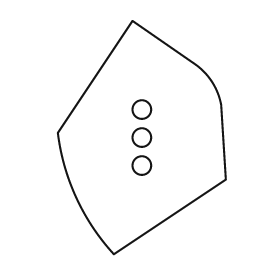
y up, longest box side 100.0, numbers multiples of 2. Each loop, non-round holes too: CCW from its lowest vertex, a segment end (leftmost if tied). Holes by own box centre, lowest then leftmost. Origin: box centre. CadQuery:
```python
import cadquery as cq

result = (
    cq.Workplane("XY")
    .moveTo(-12.0, -50.0)
    .lineTo(36.0, -18.0)
    .lineTo(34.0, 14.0)
    .threePointArc((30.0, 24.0), (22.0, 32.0))
    .lineTo(-4.0, 50.0)
    .lineTo(-36.0, 2.0)
    .threePointArc((-28.0, -26.0), (-12.0, -50.0))
    .close()
    .moveTo(0.0, -12.0)
    .circle(4.0)
    .moveTo(0.0, 0.0)
    .circle(4.0)
    .moveTo(0.0, 12.0)
    .circle(4.0)
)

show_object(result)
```